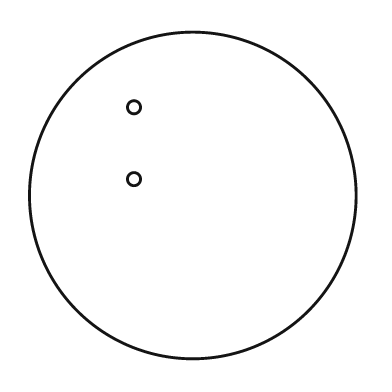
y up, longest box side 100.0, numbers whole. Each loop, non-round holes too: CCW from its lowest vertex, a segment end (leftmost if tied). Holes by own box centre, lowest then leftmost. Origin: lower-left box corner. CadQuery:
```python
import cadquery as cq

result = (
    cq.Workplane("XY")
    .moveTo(50.0, 50.0)
    .circle(50.0)
    .moveTo(32.0, 55.0)
    .circle(2.0)
    .moveTo(32.0, 77.0)
    .circle(2.0)
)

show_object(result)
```